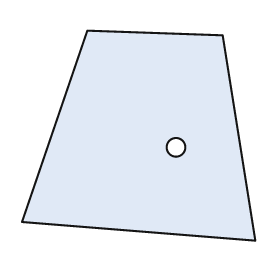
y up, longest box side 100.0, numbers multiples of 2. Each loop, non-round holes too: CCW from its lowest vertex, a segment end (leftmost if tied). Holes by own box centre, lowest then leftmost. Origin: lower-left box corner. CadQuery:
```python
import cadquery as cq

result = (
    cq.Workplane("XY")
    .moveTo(100.0, 0.0)
    .lineTo(86.0, 88.0)
    .lineTo(28.0, 90.0)
    .lineTo(0.0, 8.0)
    .close()
    .moveTo(66.0, 40.0)
    .circle(4.0)
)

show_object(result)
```